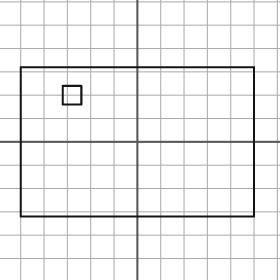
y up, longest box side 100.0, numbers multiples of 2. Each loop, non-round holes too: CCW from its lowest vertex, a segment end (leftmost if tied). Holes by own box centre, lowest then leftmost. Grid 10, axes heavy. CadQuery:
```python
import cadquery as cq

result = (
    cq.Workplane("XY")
    .moveTo(-50.0, -32.0)
    .lineTo(50.0, -32.0)
    .lineTo(50.0, 32.0)
    .lineTo(-50.0, 32.0)
    .close()
    .moveTo(-32.0, 16.0)
    .lineTo(-24.0, 16.0)
    .lineTo(-24.0, 24.0)
    .lineTo(-32.0, 24.0)
    .close()
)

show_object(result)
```